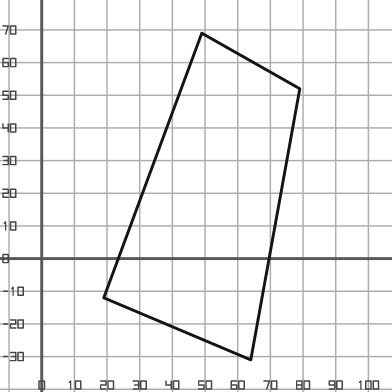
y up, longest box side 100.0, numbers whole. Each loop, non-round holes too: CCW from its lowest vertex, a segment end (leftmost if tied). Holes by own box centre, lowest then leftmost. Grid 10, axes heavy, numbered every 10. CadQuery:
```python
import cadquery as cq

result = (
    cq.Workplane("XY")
    .moveTo(64.0, -31.0)
    .lineTo(79.0, 52.0)
    .lineTo(49.0, 69.0)
    .lineTo(19.0, -12.0)
    .close()
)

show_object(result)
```